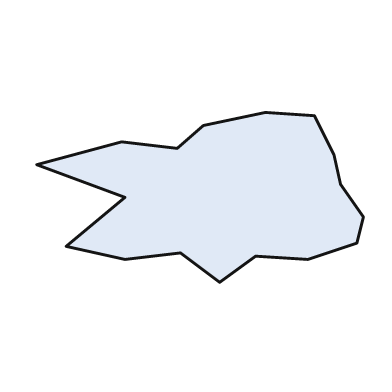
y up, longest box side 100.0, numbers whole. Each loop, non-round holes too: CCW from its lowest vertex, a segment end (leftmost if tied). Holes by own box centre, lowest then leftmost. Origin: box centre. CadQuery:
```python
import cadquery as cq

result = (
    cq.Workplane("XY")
    .moveTo(6.0, -26.0)
    .lineTo(17.0, -18.0)
    .lineTo(33.0, -19.0)
    .lineTo(48.0, -14.0)
    .lineTo(50.0, -6.0)
    .lineTo(43.0, 4.0)
    .lineTo(41.0, 13.0)
    .lineTo(35.0, 25.0)
    .lineTo(20.0, 26.0)
    .lineTo(1.0, 22.0)
    .lineTo(-7.0, 15.0)
    .lineTo(-24.0, 17.0)
    .lineTo(-50.0, 10.0)
    .lineTo(-23.0, 0.0)
    .lineTo(-41.0, -15.0)
    .lineTo(-23.0, -19.0)
    .lineTo(-6.0, -17.0)
    .close()
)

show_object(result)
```